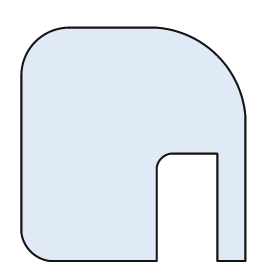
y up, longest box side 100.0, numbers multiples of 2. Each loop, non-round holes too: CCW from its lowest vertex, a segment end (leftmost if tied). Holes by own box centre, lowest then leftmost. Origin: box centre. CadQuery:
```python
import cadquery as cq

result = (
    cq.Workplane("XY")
    .moveTo(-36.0, -50.0)
    .lineTo(10.0, -50.0)
    .lineTo(10.0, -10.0)
    .threePointArc((12.0, -6.0), (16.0, -4.0))
    .lineTo(36.0, -4.0)
    .lineTo(36.0, -50.0)
    .lineTo(48.0, -50.0)
    .lineTo(48.0, 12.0)
    .threePointArc((36.0, 38.0), (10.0, 50.0))
    .lineTo(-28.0, 50.0)
    .threePointArc((-42.0, 44.0), (-48.0, 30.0))
    .lineTo(-48.0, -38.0)
    .threePointArc((-44.0, -46.0), (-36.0, -50.0))
    .close()
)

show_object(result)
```